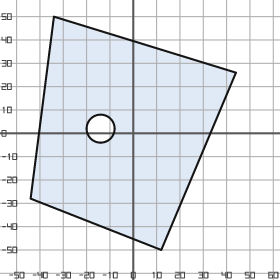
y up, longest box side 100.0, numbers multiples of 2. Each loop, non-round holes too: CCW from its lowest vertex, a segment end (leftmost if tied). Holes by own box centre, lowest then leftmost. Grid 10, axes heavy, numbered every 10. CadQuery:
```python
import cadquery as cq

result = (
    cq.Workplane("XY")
    .moveTo(12.0, -50.0)
    .lineTo(44.0, 26.0)
    .lineTo(-34.0, 50.0)
    .lineTo(-44.0, -28.0)
    .close()
    .moveTo(-14.0, 2.0)
    .circle(6.0)
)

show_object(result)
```